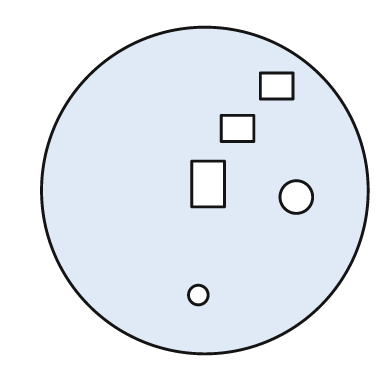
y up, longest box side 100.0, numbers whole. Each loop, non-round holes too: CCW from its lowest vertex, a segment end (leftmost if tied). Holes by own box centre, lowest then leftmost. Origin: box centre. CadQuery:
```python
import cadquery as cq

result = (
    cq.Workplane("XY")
    .moveTo(0.0, 0.0)
    .circle(50.0)
    .moveTo(-2.0, -32.0)
    .circle(3.0)
    .moveTo(28.0, -2.0)
    .circle(5.0)
    .moveTo(-4.0, -5.0)
    .lineTo(6.0, -5.0)
    .lineTo(6.0, 9.0)
    .lineTo(-4.0, 9.0)
    .close()
    .moveTo(5.0, 15.0)
    .lineTo(15.0, 15.0)
    .lineTo(15.0, 23.0)
    .lineTo(5.0, 23.0)
    .close()
    .moveTo(17.0, 28.0)
    .lineTo(27.0, 28.0)
    .lineTo(27.0, 36.0)
    .lineTo(17.0, 36.0)
    .close()
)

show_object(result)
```